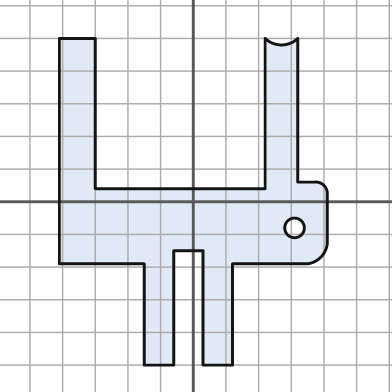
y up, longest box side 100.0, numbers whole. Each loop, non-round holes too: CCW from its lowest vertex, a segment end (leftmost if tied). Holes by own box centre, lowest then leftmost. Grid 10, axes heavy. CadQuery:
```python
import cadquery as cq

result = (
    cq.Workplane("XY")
    .moveTo(-15.0, -50.0)
    .lineTo(-6.0, -50.0)
    .lineTo(-6.0, -15.0)
    .lineTo(3.0, -15.0)
    .lineTo(3.0, -50.0)
    .lineTo(12.0, -50.0)
    .lineTo(12.0, -19.0)
    .lineTo(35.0, -19.0)
    .threePointArc((39.0, -17.0), (41.0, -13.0))
    .lineTo(41.0, 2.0)
    .threePointArc((40.0, 5.0), (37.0, 6.0))
    .lineTo(32.0, 6.0)
    .lineTo(32.0, 50.0)
    .threePointArc((27.0, 48.0), (22.0, 50.0))
    .lineTo(22.0, 4.0)
    .lineTo(-30.0, 4.0)
    .lineTo(-30.0, 50.0)
    .lineTo(-41.0, 50.0)
    .lineTo(-41.0, -19.0)
    .lineTo(-15.0, -19.0)
    .close()
    .moveTo(31.0, -8.0)
    .circle(3.0)
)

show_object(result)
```